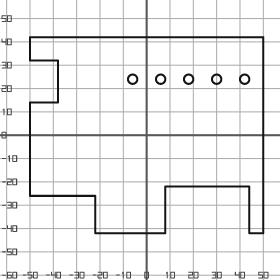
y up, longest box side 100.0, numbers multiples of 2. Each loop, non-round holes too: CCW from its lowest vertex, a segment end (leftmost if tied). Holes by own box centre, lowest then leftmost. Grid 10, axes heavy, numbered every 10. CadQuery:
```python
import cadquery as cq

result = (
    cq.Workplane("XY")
    .moveTo(-22.0, -42.0)
    .lineTo(8.0, -42.0)
    .lineTo(8.0, -22.0)
    .lineTo(44.0, -22.0)
    .lineTo(44.0, -42.0)
    .lineTo(50.0, -42.0)
    .lineTo(50.0, 42.0)
    .lineTo(-50.0, 42.0)
    .lineTo(-50.0, 32.0)
    .lineTo(-38.0, 32.0)
    .lineTo(-38.0, 14.0)
    .lineTo(-50.0, 14.0)
    .lineTo(-50.0, -26.0)
    .lineTo(-22.0, -26.0)
    .close()
    .moveTo(-6.0, 24.0)
    .circle(2.0)
    .moveTo(6.0, 24.0)
    .circle(2.0)
    .moveTo(18.0, 24.0)
    .circle(2.0)
    .moveTo(30.0, 24.0)
    .circle(2.0)
    .moveTo(42.0, 24.0)
    .circle(2.0)
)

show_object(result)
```